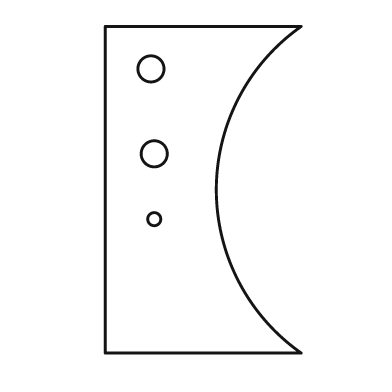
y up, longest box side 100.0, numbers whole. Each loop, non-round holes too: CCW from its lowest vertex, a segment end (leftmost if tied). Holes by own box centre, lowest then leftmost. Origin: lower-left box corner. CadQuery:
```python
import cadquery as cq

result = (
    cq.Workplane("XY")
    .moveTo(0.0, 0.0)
    .lineTo(60.0, 0.0)
    .threePointArc((34.0, 50.0), (60.0, 100.0))
    .lineTo(0.0, 100.0)
    .close()
    .moveTo(15.0, 41.0)
    .circle(2.0)
    .moveTo(15.0, 61.0)
    .circle(4.0)
    .moveTo(14.0, 87.0)
    .circle(4.0)
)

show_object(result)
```